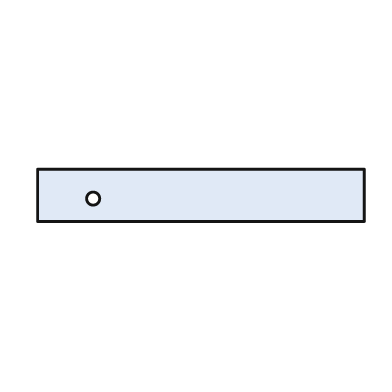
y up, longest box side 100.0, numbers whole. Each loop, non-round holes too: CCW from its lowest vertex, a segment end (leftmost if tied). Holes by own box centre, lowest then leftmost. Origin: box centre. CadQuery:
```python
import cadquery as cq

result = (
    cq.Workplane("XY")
    .moveTo(-50.0, -8.0)
    .lineTo(50.0, -8.0)
    .lineTo(50.0, 8.0)
    .lineTo(-50.0, 8.0)
    .close()
    .moveTo(-33.0, -1.0)
    .circle(2.0)
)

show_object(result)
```